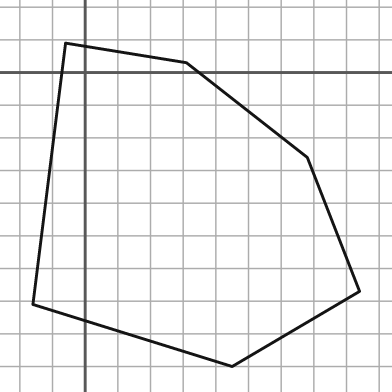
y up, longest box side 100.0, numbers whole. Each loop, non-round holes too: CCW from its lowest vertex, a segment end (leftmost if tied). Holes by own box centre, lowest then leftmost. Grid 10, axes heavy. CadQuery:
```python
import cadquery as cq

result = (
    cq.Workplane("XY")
    .moveTo(45.0, -90.0)
    .lineTo(84.0, -67.0)
    .lineTo(68.0, -26.0)
    .lineTo(31.0, 3.0)
    .lineTo(-6.0, 9.0)
    .lineTo(-16.0, -71.0)
    .close()
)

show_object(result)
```